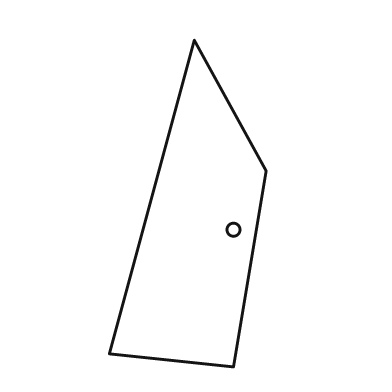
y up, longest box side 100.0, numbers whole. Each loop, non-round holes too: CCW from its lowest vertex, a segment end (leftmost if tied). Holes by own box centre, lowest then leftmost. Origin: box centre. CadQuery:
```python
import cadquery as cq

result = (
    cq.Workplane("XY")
    .moveTo(14.0, -50.0)
    .lineTo(24.0, 10.0)
    .lineTo(2.0, 50.0)
    .lineTo(-24.0, -46.0)
    .close()
    .moveTo(14.0, -8.0)
    .circle(2.0)
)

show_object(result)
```